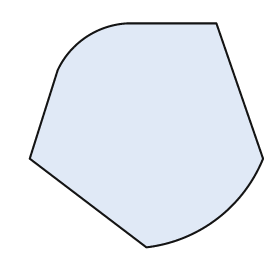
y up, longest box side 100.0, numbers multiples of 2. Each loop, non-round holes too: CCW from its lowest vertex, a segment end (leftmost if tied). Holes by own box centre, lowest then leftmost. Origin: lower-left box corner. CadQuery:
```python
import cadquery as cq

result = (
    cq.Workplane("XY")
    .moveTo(50.0, 0.0)
    .threePointArc((80.0, 12.0), (100.0, 38.0))
    .lineTo(80.0, 96.0)
    .lineTo(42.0, 96.0)
    .threePointArc((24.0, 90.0), (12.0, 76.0))
    .lineTo(0.0, 38.0)
    .close()
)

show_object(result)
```